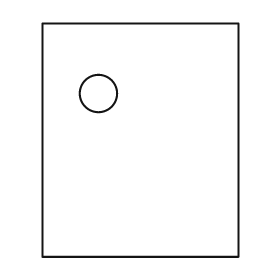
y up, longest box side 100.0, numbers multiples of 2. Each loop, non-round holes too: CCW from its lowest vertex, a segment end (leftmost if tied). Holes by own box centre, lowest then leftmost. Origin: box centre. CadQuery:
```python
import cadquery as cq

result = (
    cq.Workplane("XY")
    .moveTo(-42.0, -50.0)
    .lineTo(42.0, -50.0)
    .lineTo(42.0, 50.0)
    .lineTo(-42.0, 50.0)
    .close()
    .moveTo(-18.0, 20.0)
    .circle(8.0)
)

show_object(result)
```